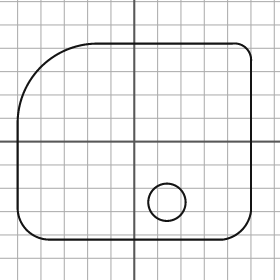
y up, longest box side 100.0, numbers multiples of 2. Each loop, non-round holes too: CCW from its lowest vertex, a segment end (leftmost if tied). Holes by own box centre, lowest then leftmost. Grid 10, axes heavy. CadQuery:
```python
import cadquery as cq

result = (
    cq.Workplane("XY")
    .moveTo(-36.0, -42.0)
    .lineTo(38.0, -42.0)
    .threePointArc((46.0, -38.0), (50.0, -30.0))
    .lineTo(50.0, 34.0)
    .threePointArc((48.0, 40.0), (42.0, 42.0))
    .lineTo(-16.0, 42.0)
    .threePointArc((-40.0, 32.0), (-50.0, 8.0))
    .lineTo(-50.0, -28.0)
    .threePointArc((-46.0, -38.0), (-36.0, -42.0))
    .close()
    .moveTo(14.0, -26.0)
    .circle(8.0)
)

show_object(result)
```